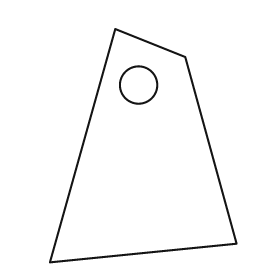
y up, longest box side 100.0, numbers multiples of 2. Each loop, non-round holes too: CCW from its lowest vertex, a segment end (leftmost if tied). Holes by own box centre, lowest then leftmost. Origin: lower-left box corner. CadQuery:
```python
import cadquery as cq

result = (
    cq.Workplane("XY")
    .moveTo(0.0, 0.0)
    .lineTo(80.0, 8.0)
    .lineTo(58.0, 88.0)
    .lineTo(28.0, 100.0)
    .close()
    .moveTo(38.0, 76.0)
    .circle(8.0)
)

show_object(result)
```